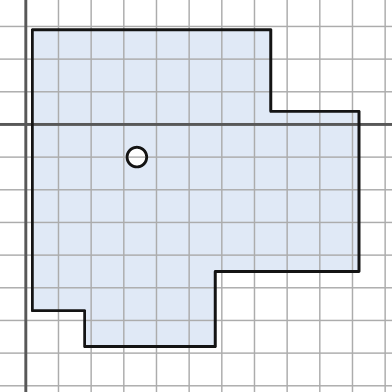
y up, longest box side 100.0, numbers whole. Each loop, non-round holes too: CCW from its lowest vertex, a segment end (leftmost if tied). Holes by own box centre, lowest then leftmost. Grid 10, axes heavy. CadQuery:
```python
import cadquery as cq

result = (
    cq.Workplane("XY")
    .moveTo(18.0, -68.0)
    .lineTo(58.0, -68.0)
    .lineTo(58.0, -45.0)
    .lineTo(102.0, -45.0)
    .lineTo(102.0, 4.0)
    .lineTo(75.0, 4.0)
    .lineTo(75.0, 29.0)
    .lineTo(2.0, 29.0)
    .lineTo(2.0, -57.0)
    .lineTo(18.0, -57.0)
    .close()
    .moveTo(34.0, -10.0)
    .circle(3.0)
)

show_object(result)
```